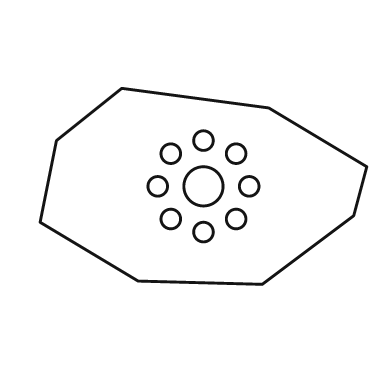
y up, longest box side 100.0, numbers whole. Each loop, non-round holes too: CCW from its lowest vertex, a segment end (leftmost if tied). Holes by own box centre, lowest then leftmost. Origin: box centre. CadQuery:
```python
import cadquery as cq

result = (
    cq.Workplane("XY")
    .moveTo(18.0, -30.0)
    .lineTo(46.0, -9.0)
    .lineTo(50.0, 6.0)
    .lineTo(20.0, 24.0)
    .lineTo(-25.0, 30.0)
    .lineTo(-45.0, 14.0)
    .lineTo(-50.0, -11.0)
    .lineTo(-20.0, -29.0)
    .close()
    .moveTo(0.0, -14.0)
    .circle(3.0)
    .moveTo(-10.0, -10.0)
    .circle(3.0)
    .moveTo(10.0, -10.0)
    .circle(3.0)
    .moveTo(-14.0, 0.0)
    .circle(3.0)
    .moveTo(0.0, 0.0)
    .circle(6.0)
    .moveTo(14.0, 0.0)
    .circle(3.0)
    .moveTo(-10.0, 10.0)
    .circle(3.0)
    .moveTo(10.0, 10.0)
    .circle(3.0)
    .moveTo(0.0, 14.0)
    .circle(3.0)
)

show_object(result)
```